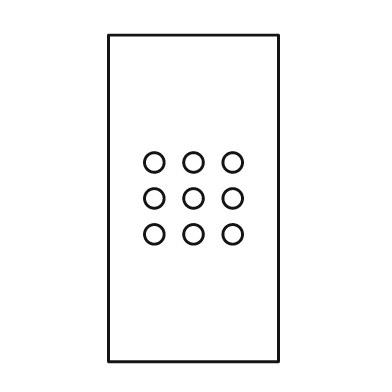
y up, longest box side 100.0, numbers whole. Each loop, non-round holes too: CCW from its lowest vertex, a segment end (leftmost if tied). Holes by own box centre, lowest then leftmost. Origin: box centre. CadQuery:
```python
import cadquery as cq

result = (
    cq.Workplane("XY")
    .moveTo(-26.0, -50.0)
    .lineTo(26.0, -50.0)
    .lineTo(26.0, 50.0)
    .lineTo(-26.0, 50.0)
    .close()
    .moveTo(-12.0, -11.0)
    .circle(3.0)
    .moveTo(0.0, -11.0)
    .circle(3.0)
    .moveTo(12.0, -11.0)
    .circle(3.0)
    .moveTo(-12.0, 0.0)
    .circle(3.0)
    .moveTo(0.0, 0.0)
    .circle(3.0)
    .moveTo(12.0, 0.0)
    .circle(3.0)
    .moveTo(-12.0, 11.0)
    .circle(3.0)
    .moveTo(0.0, 11.0)
    .circle(3.0)
    .moveTo(12.0, 11.0)
    .circle(3.0)
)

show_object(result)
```